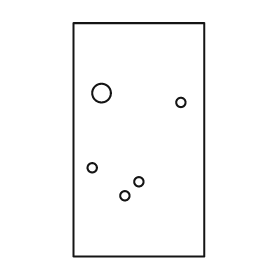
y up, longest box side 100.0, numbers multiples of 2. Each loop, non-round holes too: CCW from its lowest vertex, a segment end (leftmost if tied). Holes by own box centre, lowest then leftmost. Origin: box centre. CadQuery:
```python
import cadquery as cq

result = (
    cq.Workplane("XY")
    .moveTo(-28.0, -50.0)
    .lineTo(28.0, -50.0)
    .lineTo(28.0, 50.0)
    .lineTo(-28.0, 50.0)
    .close()
    .moveTo(-6.0, -24.0)
    .circle(2.0)
    .moveTo(0.0, -18.0)
    .circle(2.0)
    .moveTo(-20.0, -12.0)
    .circle(2.0)
    .moveTo(18.0, 16.0)
    .circle(2.0)
    .moveTo(-16.0, 20.0)
    .circle(4.0)
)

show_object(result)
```